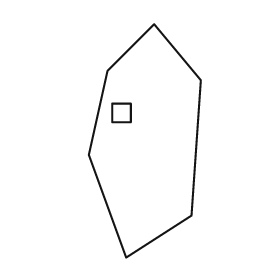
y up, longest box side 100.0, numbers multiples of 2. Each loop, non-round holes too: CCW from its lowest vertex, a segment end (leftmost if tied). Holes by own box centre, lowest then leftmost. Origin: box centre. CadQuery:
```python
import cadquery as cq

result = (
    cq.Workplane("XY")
    .moveTo(-8.0, -50.0)
    .lineTo(20.0, -32.0)
    .lineTo(24.0, 26.0)
    .lineTo(4.0, 50.0)
    .lineTo(-16.0, 30.0)
    .lineTo(-24.0, -6.0)
    .close()
    .moveTo(-14.0, 8.0)
    .lineTo(-6.0, 8.0)
    .lineTo(-6.0, 16.0)
    .lineTo(-14.0, 16.0)
    .close()
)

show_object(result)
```